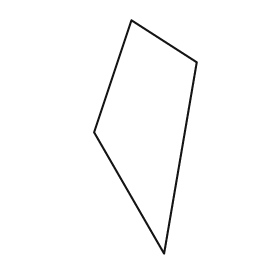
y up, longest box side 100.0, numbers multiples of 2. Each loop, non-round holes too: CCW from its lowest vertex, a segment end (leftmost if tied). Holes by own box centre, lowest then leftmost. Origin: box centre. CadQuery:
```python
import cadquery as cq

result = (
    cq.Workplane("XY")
    .moveTo(8.0, -50.0)
    .lineTo(22.0, 32.0)
    .lineTo(-6.0, 50.0)
    .lineTo(-22.0, 2.0)
    .close()
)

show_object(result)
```